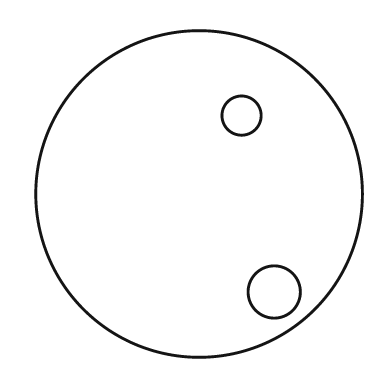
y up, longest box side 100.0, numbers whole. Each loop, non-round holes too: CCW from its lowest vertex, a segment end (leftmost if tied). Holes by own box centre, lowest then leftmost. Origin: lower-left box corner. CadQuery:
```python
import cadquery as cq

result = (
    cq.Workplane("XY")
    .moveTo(50.0, 50.0)
    .circle(50.0)
    .moveTo(73.0, 20.0)
    .circle(8.0)
    .moveTo(63.0, 74.0)
    .circle(6.0)
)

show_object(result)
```